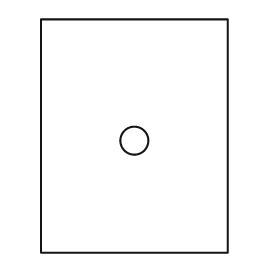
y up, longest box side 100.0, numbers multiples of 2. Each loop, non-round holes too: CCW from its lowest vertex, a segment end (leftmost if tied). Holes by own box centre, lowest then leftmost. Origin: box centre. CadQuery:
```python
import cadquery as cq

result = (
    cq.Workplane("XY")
    .moveTo(-40.0, -50.0)
    .lineTo(40.0, -50.0)
    .lineTo(40.0, 50.0)
    .lineTo(-40.0, 50.0)
    .close()
    .moveTo(0.0, -2.0)
    .circle(6.0)
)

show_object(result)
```